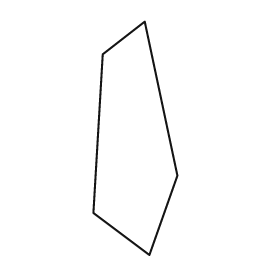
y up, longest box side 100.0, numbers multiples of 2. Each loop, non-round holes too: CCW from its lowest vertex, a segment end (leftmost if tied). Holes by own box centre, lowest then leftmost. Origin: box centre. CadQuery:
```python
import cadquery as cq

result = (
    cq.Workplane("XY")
    .moveTo(6.0, -50.0)
    .lineTo(18.0, -16.0)
    .lineTo(4.0, 50.0)
    .lineTo(-14.0, 36.0)
    .lineTo(-18.0, -32.0)
    .close()
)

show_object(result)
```